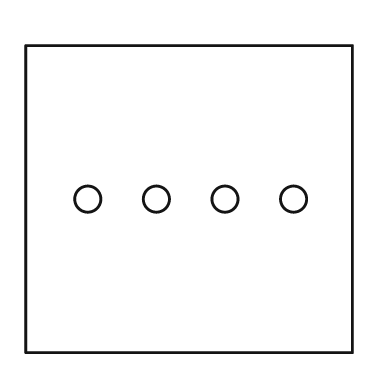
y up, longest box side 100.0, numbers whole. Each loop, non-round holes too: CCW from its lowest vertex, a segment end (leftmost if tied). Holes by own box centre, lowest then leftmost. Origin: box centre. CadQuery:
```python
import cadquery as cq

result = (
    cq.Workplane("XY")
    .moveTo(-50.0, -47.0)
    .lineTo(50.0, -47.0)
    .lineTo(50.0, 47.0)
    .lineTo(-50.0, 47.0)
    .close()
    .moveTo(-31.0, 0.0)
    .circle(4.0)
    .moveTo(-10.0, 0.0)
    .circle(4.0)
    .moveTo(11.0, 0.0)
    .circle(4.0)
    .moveTo(32.0, 0.0)
    .circle(4.0)
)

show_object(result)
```